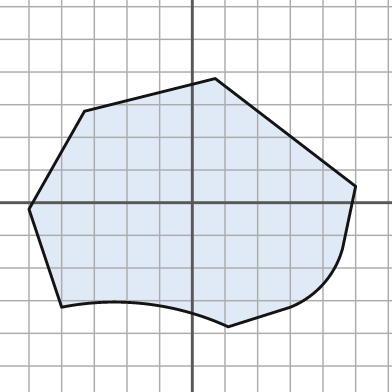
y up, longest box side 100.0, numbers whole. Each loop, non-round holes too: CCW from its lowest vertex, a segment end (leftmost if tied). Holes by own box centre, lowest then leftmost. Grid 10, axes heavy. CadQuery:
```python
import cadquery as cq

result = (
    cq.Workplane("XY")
    .moveTo(11.0, -38.0)
    .lineTo(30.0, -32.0)
    .threePointArc((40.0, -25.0), (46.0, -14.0))
    .lineTo(50.0, 5.0)
    .lineTo(7.0, 38.0)
    .lineTo(-33.0, 28.0)
    .lineTo(-50.0, -2.0)
    .lineTo(-40.0, -32.0)
    .threePointArc((-14.0, -31.0), (11.0, -38.0))
    .close()
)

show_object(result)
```